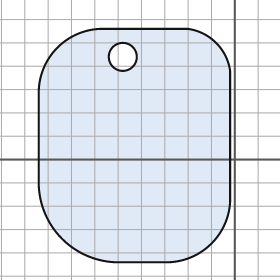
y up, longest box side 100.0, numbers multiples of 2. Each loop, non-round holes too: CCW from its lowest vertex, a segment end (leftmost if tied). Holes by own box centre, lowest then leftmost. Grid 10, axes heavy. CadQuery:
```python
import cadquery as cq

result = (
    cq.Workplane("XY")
    .moveTo(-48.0, -44.0)
    .lineTo(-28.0, -44.0)
    .threePointArc((-10.0, -36.0), (-2.0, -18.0))
    .lineTo(-2.0, 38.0)
    .threePointArc((-8.0, 50.0), (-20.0, 56.0))
    .lineTo(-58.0, 56.0)
    .threePointArc((-76.0, 48.0), (-84.0, 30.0))
    .lineTo(-84.0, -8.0)
    .threePointArc((-74.0, -34.0), (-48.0, -44.0))
    .close()
    .moveTo(-48.0, 44.0)
    .circle(6.0)
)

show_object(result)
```